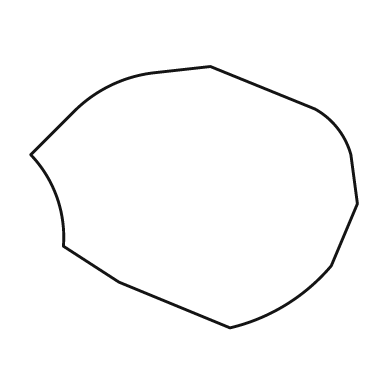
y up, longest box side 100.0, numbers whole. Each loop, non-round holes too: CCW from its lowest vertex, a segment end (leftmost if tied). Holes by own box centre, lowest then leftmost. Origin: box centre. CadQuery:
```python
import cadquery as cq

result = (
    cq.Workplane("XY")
    .moveTo(11.0, -40.0)
    .threePointArc((28.0, -33.0), (42.0, -21.0))
    .lineTo(50.0, -2.0)
    .lineTo(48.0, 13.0)
    .threePointArc((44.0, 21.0), (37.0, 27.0))
    .lineTo(5.0, 40.0)
    .lineTo(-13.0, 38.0)
    .threePointArc((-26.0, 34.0), (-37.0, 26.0))
    .lineTo(-50.0, 13.0)
    .threePointArc((-42.0, 0.0), (-40.0, -15.0))
    .lineTo(-23.0, -26.0)
    .close()
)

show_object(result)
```